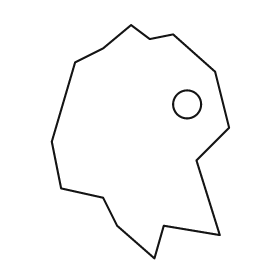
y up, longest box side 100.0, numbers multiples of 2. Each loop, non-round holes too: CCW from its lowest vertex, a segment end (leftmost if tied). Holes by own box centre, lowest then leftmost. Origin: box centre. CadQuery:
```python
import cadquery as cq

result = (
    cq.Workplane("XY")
    .moveTo(6.0, -50.0)
    .lineTo(10.0, -36.0)
    .lineTo(34.0, -40.0)
    .lineTo(24.0, -8.0)
    .lineTo(38.0, 6.0)
    .lineTo(32.0, 30.0)
    .lineTo(14.0, 46.0)
    .lineTo(4.0, 44.0)
    .lineTo(-4.0, 50.0)
    .lineTo(-16.0, 40.0)
    .lineTo(-28.0, 34.0)
    .lineTo(-38.0, 0.0)
    .lineTo(-34.0, -20.0)
    .lineTo(-16.0, -24.0)
    .lineTo(-10.0, -36.0)
    .close()
    .moveTo(20.0, 16.0)
    .circle(6.0)
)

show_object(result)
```